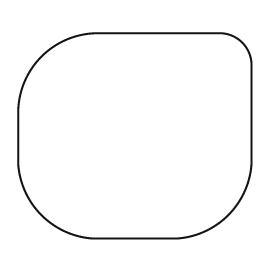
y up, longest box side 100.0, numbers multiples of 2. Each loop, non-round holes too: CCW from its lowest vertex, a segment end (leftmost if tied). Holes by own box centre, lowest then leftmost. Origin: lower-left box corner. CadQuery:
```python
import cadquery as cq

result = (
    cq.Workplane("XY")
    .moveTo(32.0, 0.0)
    .lineTo(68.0, 0.0)
    .threePointArc((90.0, 10.0), (100.0, 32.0))
    .lineTo(100.0, 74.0)
    .threePointArc((96.0, 84.0), (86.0, 88.0))
    .lineTo(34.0, 88.0)
    .threePointArc((10.0, 78.0), (0.0, 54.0))
    .lineTo(0.0, 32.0)
    .threePointArc((10.0, 10.0), (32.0, 0.0))
    .close()
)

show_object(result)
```